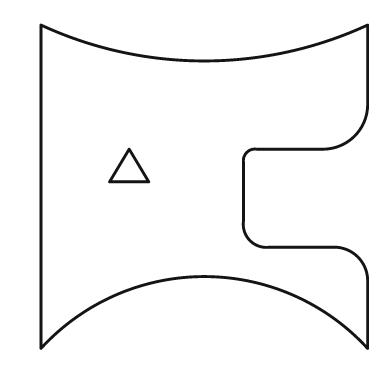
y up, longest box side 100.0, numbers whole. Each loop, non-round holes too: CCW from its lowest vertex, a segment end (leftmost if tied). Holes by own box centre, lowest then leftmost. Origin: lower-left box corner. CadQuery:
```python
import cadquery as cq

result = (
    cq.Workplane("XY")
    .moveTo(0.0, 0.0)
    .threePointArc((50.0, 22.0), (100.0, 0.0))
    .lineTo(100.0, 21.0)
    .threePointArc((97.0, 28.0), (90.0, 31.0))
    .lineTo(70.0, 31.0)
    .threePointArc((64.0, 33.0), (62.0, 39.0))
    .lineTo(62.0, 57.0)
    .threePointArc((63.0, 60.0), (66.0, 61.0))
    .lineTo(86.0, 61.0)
    .threePointArc((96.0, 65.0), (100.0, 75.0))
    .lineTo(100.0, 99.0)
    .threePointArc((50.0, 88.0), (0.0, 99.0))
    .close()
    .moveTo(21.0, 51.0)
    .lineTo(33.0, 51.0)
    .lineTo(27.0, 61.0)
    .close()
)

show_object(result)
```